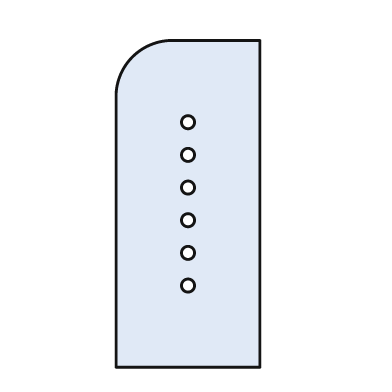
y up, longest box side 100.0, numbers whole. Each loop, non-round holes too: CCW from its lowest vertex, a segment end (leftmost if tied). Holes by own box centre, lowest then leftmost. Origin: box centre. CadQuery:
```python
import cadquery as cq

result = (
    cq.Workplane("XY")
    .moveTo(-22.0, -50.0)
    .lineTo(22.0, -50.0)
    .lineTo(22.0, 50.0)
    .lineTo(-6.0, 50.0)
    .threePointArc((-17.0, 45.0), (-22.0, 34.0))
    .close()
    .moveTo(0.0, -25.0)
    .circle(2.0)
    .moveTo(0.0, -15.0)
    .circle(2.0)
    .moveTo(0.0, -5.0)
    .circle(2.0)
    .moveTo(0.0, 5.0)
    .circle(2.0)
    .moveTo(0.0, 15.0)
    .circle(2.0)
    .moveTo(0.0, 25.0)
    .circle(2.0)
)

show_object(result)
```